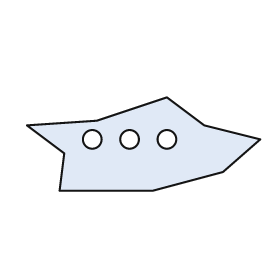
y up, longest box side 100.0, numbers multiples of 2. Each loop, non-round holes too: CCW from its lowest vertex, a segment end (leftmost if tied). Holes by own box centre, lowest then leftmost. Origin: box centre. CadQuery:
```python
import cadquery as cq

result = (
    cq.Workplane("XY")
    .moveTo(-36.0, -20.0)
    .lineTo(4.0, -20.0)
    .lineTo(34.0, -12.0)
    .lineTo(50.0, 2.0)
    .lineTo(26.0, 8.0)
    .lineTo(10.0, 20.0)
    .lineTo(-20.0, 10.0)
    .lineTo(-50.0, 8.0)
    .lineTo(-34.0, -4.0)
    .close()
    .moveTo(-22.0, 2.0)
    .circle(4.0)
    .moveTo(-6.0, 2.0)
    .circle(4.0)
    .moveTo(10.0, 2.0)
    .circle(4.0)
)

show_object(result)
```